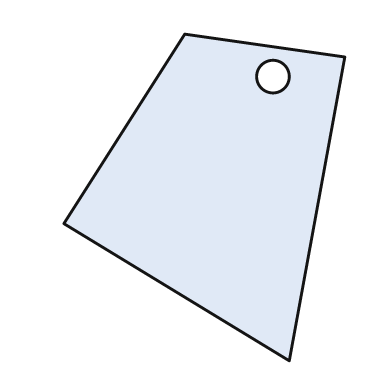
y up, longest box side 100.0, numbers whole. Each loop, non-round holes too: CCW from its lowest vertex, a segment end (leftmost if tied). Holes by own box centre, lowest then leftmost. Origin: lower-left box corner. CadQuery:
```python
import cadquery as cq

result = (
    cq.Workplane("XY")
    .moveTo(69.0, 0.0)
    .lineTo(86.0, 93.0)
    .lineTo(37.0, 100.0)
    .lineTo(0.0, 42.0)
    .close()
    .moveTo(64.0, 87.0)
    .circle(5.0)
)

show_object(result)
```